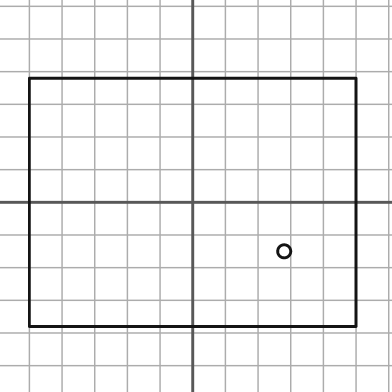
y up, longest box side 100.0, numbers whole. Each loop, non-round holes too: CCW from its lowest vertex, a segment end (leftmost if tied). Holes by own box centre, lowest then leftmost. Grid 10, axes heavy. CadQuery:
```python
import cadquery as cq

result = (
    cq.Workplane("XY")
    .moveTo(-50.0, -38.0)
    .lineTo(50.0, -38.0)
    .lineTo(50.0, 38.0)
    .lineTo(-50.0, 38.0)
    .close()
    .moveTo(28.0, -15.0)
    .circle(2.0)
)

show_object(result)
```